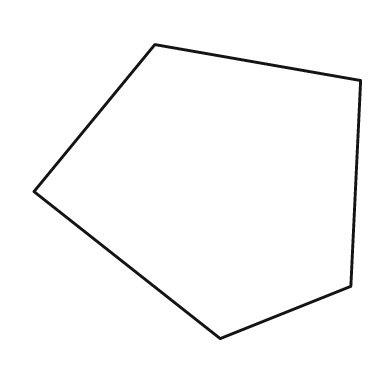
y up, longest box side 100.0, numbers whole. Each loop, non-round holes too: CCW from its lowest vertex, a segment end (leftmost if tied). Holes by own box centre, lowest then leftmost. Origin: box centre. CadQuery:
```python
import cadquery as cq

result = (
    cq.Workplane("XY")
    .moveTo(7.0, -45.0)
    .lineTo(47.0, -29.0)
    .lineTo(50.0, 34.0)
    .lineTo(-13.0, 45.0)
    .lineTo(-50.0, 0.0)
    .close()
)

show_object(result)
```